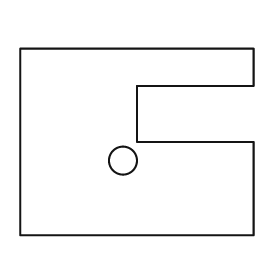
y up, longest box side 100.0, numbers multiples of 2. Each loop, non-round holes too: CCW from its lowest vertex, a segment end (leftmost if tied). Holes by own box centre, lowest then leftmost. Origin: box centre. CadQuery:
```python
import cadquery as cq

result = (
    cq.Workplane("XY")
    .moveTo(-50.0, -40.0)
    .lineTo(50.0, -40.0)
    .lineTo(50.0, 0.0)
    .lineTo(0.0, 0.0)
    .lineTo(0.0, 24.0)
    .lineTo(50.0, 24.0)
    .lineTo(50.0, 40.0)
    .lineTo(-50.0, 40.0)
    .close()
    .moveTo(-6.0, -8.0)
    .circle(6.0)
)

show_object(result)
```